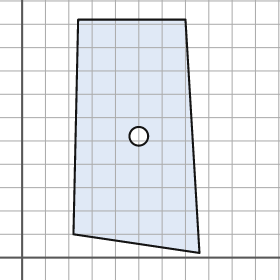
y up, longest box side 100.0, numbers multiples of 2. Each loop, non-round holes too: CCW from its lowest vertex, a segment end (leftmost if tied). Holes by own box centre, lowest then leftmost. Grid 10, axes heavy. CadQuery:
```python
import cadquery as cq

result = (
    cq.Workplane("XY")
    .moveTo(76.0, 2.0)
    .lineTo(70.0, 102.0)
    .lineTo(24.0, 102.0)
    .lineTo(22.0, 10.0)
    .close()
    .moveTo(50.0, 52.0)
    .circle(4.0)
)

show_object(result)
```